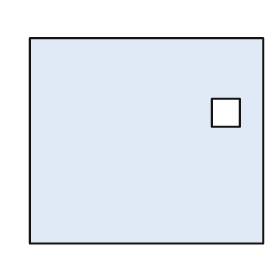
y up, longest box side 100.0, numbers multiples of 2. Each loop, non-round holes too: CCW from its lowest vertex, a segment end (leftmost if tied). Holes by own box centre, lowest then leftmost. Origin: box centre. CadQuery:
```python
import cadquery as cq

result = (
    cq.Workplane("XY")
    .moveTo(-50.0, -44.0)
    .lineTo(50.0, -44.0)
    .lineTo(50.0, 44.0)
    .lineTo(-50.0, 44.0)
    .close()
    .moveTo(28.0, 6.0)
    .lineTo(40.0, 6.0)
    .lineTo(40.0, 18.0)
    .lineTo(28.0, 18.0)
    .close()
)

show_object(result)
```